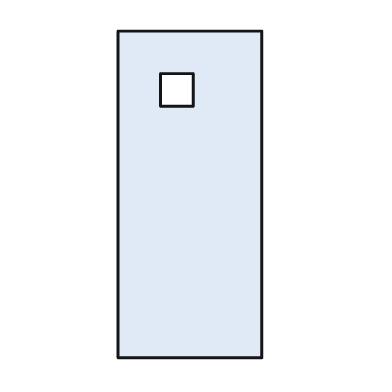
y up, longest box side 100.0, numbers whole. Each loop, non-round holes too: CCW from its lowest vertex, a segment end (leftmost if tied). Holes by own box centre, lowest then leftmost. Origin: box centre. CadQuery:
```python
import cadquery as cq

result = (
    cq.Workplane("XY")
    .moveTo(-22.0, -50.0)
    .lineTo(22.0, -50.0)
    .lineTo(22.0, 50.0)
    .lineTo(-22.0, 50.0)
    .close()
    .moveTo(-9.0, 27.0)
    .lineTo(1.0, 27.0)
    .lineTo(1.0, 37.0)
    .lineTo(-9.0, 37.0)
    .close()
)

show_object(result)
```